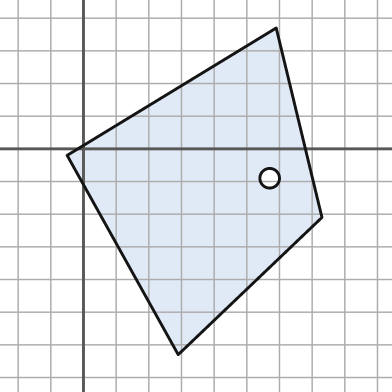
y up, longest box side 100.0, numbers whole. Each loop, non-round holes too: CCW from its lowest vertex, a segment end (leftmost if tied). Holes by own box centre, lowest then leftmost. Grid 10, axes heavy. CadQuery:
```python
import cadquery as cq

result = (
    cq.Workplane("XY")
    .moveTo(29.0, -63.0)
    .lineTo(73.0, -21.0)
    .lineTo(59.0, 37.0)
    .lineTo(-5.0, -2.0)
    .close()
    .moveTo(57.0, -9.0)
    .circle(3.0)
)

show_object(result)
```